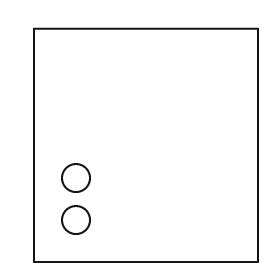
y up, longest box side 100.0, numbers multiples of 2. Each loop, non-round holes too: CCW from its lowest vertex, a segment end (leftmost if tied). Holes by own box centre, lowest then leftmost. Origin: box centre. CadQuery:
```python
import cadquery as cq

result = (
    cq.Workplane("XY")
    .moveTo(-48.0, -50.0)
    .lineTo(48.0, -50.0)
    .lineTo(48.0, 50.0)
    .lineTo(-48.0, 50.0)
    .close()
    .moveTo(-30.0, -32.0)
    .circle(6.0)
    .moveTo(-30.0, -14.0)
    .circle(6.0)
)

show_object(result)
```